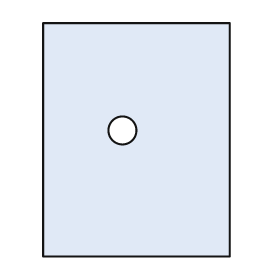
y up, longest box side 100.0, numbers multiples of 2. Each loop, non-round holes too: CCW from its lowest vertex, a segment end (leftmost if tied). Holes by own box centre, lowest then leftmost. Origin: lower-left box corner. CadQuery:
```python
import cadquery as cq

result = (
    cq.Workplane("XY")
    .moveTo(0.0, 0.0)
    .lineTo(80.0, 0.0)
    .lineTo(80.0, 100.0)
    .lineTo(0.0, 100.0)
    .close()
    .moveTo(34.0, 54.0)
    .circle(6.0)
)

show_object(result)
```